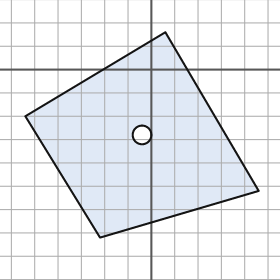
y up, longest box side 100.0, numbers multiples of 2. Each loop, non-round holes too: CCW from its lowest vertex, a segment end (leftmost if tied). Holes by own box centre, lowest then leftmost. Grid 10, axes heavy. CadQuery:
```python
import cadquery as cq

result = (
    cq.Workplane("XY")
    .moveTo(-22.0, -72.0)
    .lineTo(46.0, -52.0)
    .lineTo(6.0, 16.0)
    .lineTo(-54.0, -20.0)
    .close()
    .moveTo(-4.0, -28.0)
    .circle(4.0)
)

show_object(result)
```